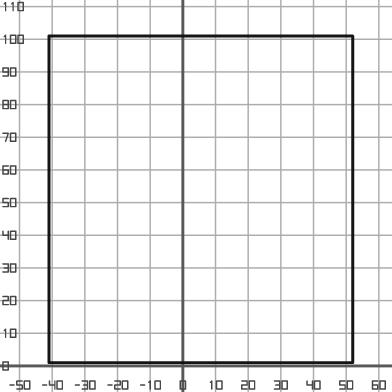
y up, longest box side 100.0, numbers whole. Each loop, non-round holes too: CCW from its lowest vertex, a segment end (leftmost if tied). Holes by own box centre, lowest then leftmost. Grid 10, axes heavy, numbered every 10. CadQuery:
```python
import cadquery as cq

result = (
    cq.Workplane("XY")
    .moveTo(-41.0, 1.0)
    .lineTo(52.0, 1.0)
    .lineTo(52.0, 101.0)
    .lineTo(-41.0, 101.0)
    .close()
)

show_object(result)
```